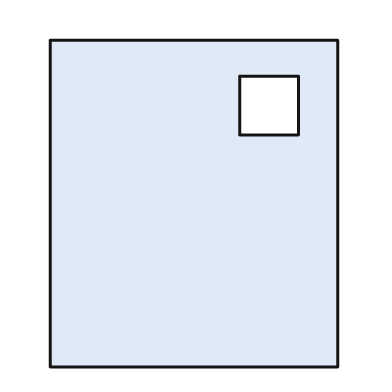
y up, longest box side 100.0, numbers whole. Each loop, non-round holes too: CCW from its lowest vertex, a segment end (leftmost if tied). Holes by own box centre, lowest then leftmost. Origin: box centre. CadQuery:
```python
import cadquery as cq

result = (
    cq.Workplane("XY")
    .moveTo(-44.0, -50.0)
    .lineTo(44.0, -50.0)
    .lineTo(44.0, 50.0)
    .lineTo(-44.0, 50.0)
    .close()
    .moveTo(14.0, 21.0)
    .lineTo(32.0, 21.0)
    .lineTo(32.0, 39.0)
    .lineTo(14.0, 39.0)
    .close()
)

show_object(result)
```